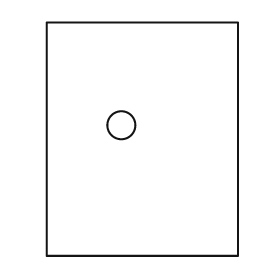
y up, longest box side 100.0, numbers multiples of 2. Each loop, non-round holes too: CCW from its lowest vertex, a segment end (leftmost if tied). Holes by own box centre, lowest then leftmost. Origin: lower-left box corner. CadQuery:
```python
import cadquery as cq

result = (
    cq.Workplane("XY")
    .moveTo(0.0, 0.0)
    .lineTo(82.0, 0.0)
    .lineTo(82.0, 100.0)
    .lineTo(0.0, 100.0)
    .close()
    .moveTo(32.0, 56.0)
    .circle(6.0)
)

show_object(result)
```